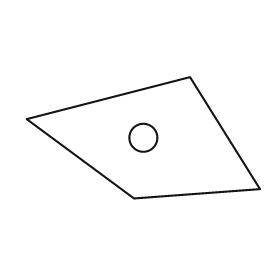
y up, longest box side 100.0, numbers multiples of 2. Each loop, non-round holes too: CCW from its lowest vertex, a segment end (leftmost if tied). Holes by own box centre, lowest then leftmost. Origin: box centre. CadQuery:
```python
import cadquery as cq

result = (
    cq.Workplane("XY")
    .moveTo(-4.0, -26.0)
    .lineTo(50.0, -22.0)
    .lineTo(20.0, 26.0)
    .lineTo(-50.0, 8.0)
    .close()
    .moveTo(0.0, 0.0)
    .circle(6.0)
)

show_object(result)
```